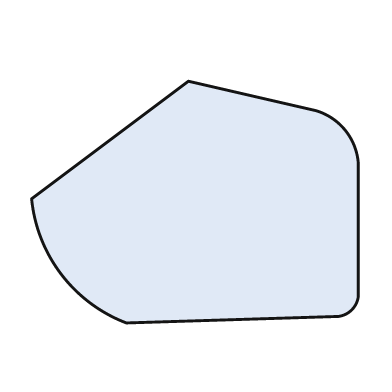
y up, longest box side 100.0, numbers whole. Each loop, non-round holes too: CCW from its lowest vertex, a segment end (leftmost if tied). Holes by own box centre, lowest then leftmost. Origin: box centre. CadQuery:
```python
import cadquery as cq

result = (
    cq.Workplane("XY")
    .moveTo(-21.0, -37.0)
    .lineTo(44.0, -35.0)
    .threePointArc((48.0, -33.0), (50.0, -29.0))
    .lineTo(50.0, 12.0)
    .threePointArc((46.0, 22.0), (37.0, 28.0))
    .lineTo(-2.0, 37.0)
    .lineTo(-50.0, 1.0)
    .threePointArc((-41.0, -22.0), (-21.0, -37.0))
    .close()
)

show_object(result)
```